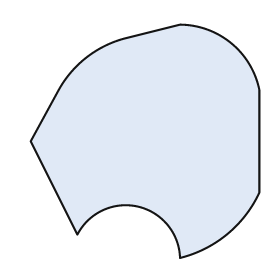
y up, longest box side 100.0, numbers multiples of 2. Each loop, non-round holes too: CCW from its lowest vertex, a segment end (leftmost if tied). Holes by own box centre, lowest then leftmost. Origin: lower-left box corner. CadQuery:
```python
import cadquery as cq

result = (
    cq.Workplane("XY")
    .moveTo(64.0, 0.0)
    .threePointArc((84.0, 10.0), (98.0, 28.0))
    .lineTo(98.0, 72.0)
    .threePointArc((86.0, 92.0), (64.0, 100.0))
    .lineTo(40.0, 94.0)
    .threePointArc((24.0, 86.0), (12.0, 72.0))
    .lineTo(0.0, 50.0)
    .lineTo(20.0, 10.0)
    .threePointArc((46.0, 22.0), (64.0, 0.0))
    .close()
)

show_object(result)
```